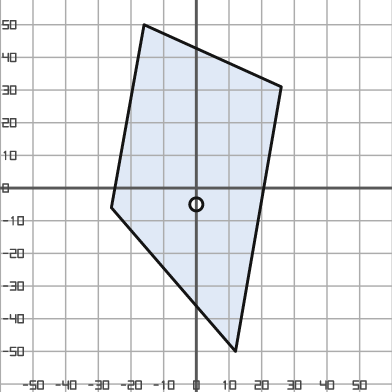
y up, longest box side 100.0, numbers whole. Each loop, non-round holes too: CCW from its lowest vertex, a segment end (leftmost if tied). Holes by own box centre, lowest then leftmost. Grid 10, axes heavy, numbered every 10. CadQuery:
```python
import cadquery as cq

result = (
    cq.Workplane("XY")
    .moveTo(12.0, -50.0)
    .lineTo(26.0, 31.0)
    .lineTo(-16.0, 50.0)
    .lineTo(-26.0, -6.0)
    .close()
    .moveTo(0.0, -5.0)
    .circle(2.0)
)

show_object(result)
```